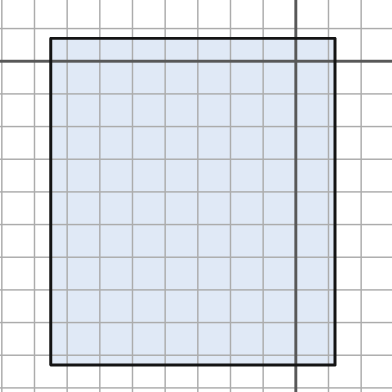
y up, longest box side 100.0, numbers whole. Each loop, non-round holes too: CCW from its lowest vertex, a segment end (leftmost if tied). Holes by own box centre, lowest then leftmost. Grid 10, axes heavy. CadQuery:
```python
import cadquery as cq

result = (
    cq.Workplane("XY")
    .moveTo(-75.0, -93.0)
    .lineTo(12.0, -93.0)
    .lineTo(12.0, 7.0)
    .lineTo(-75.0, 7.0)
    .close()
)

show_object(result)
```